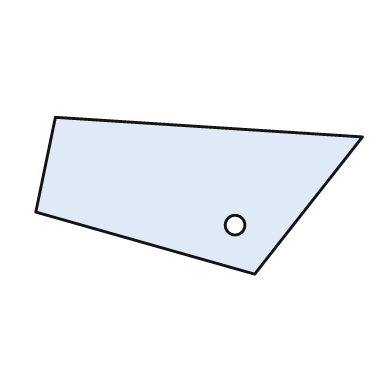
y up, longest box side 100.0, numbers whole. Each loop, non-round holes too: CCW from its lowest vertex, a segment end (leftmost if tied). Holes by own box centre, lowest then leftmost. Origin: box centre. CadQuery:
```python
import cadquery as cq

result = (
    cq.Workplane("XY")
    .moveTo(17.0, -24.0)
    .lineTo(50.0, 18.0)
    .lineTo(-44.0, 24.0)
    .lineTo(-50.0, -5.0)
    .close()
    .moveTo(11.0, -9.0)
    .circle(3.0)
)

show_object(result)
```